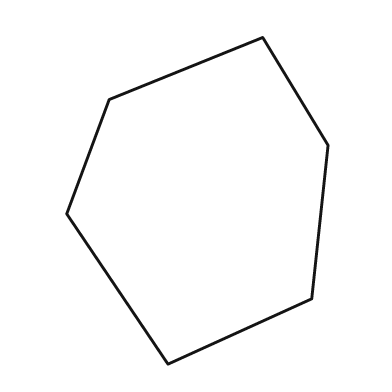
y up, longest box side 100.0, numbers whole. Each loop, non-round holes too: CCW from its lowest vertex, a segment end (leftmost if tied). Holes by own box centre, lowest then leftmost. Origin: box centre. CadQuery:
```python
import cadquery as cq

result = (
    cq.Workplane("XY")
    .moveTo(-9.0, -50.0)
    .lineTo(35.0, -30.0)
    .lineTo(40.0, 17.0)
    .lineTo(20.0, 50.0)
    .lineTo(-27.0, 31.0)
    .lineTo(-40.0, -4.0)
    .close()
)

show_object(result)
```